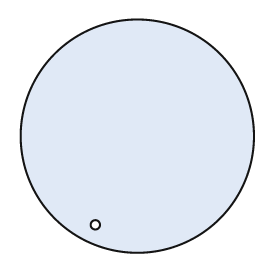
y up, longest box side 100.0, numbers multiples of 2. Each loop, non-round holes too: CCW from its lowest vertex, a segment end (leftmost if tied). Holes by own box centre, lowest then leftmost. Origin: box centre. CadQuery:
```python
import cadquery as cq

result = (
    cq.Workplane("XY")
    .moveTo(0.0, 0.0)
    .circle(50.0)
    .moveTo(-18.0, -38.0)
    .circle(2.0)
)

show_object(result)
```